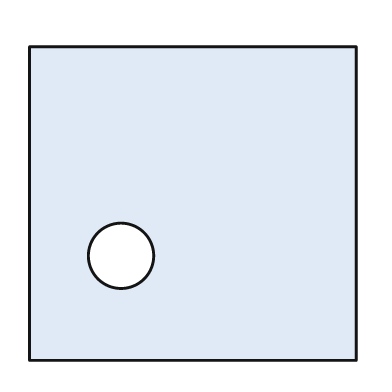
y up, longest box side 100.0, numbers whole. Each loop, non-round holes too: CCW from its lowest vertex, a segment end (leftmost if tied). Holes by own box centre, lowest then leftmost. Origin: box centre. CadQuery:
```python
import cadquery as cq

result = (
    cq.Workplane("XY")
    .moveTo(-50.0, -48.0)
    .lineTo(50.0, -48.0)
    .lineTo(50.0, 48.0)
    .lineTo(-50.0, 48.0)
    .close()
    .moveTo(-22.0, -16.0)
    .circle(10.0)
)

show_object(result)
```